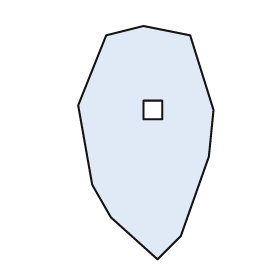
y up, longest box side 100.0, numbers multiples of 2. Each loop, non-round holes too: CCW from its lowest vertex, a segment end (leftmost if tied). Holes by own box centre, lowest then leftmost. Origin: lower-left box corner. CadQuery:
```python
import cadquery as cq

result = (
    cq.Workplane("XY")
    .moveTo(34.0, 0.0)
    .lineTo(44.0, 10.0)
    .lineTo(56.0, 44.0)
    .lineTo(58.0, 64.0)
    .lineTo(48.0, 96.0)
    .lineTo(28.0, 100.0)
    .lineTo(12.0, 96.0)
    .lineTo(0.0, 66.0)
    .lineTo(6.0, 32.0)
    .lineTo(14.0, 18.0)
    .close()
    .moveTo(28.0, 60.0)
    .lineTo(36.0, 60.0)
    .lineTo(36.0, 68.0)
    .lineTo(28.0, 68.0)
    .close()
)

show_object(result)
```